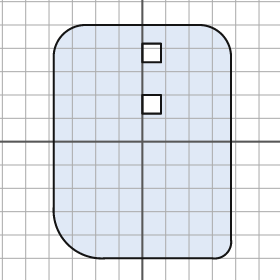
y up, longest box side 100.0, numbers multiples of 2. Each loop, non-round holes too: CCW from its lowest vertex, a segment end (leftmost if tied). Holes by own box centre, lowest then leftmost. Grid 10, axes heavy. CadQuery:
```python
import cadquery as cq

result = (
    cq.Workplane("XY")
    .moveTo(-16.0, -50.0)
    .lineTo(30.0, -50.0)
    .threePointArc((36.0, -48.0), (38.0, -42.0))
    .lineTo(38.0, 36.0)
    .threePointArc((34.0, 46.0), (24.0, 50.0))
    .lineTo(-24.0, 50.0)
    .threePointArc((-34.0, 46.0), (-38.0, 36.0))
    .lineTo(-38.0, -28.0)
    .threePointArc((-32.0, -44.0), (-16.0, -50.0))
    .close()
    .moveTo(0.0, 12.0)
    .lineTo(8.0, 12.0)
    .lineTo(8.0, 20.0)
    .lineTo(0.0, 20.0)
    .close()
    .moveTo(0.0, 34.0)
    .lineTo(8.0, 34.0)
    .lineTo(8.0, 42.0)
    .lineTo(0.0, 42.0)
    .close()
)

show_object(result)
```